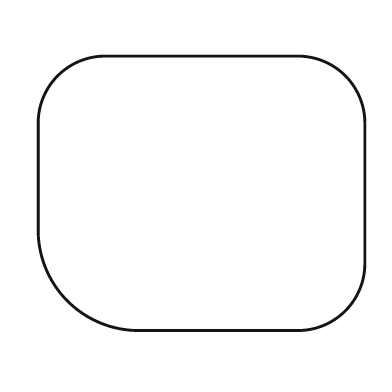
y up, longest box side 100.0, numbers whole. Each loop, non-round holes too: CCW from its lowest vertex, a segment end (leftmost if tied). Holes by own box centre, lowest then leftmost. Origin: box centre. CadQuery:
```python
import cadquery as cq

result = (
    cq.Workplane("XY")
    .moveTo(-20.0, -42.0)
    .lineTo(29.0, -42.0)
    .threePointArc((44.0, -36.0), (50.0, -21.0))
    .lineTo(50.0, 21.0)
    .threePointArc((44.0, 36.0), (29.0, 42.0))
    .lineTo(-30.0, 42.0)
    .threePointArc((-44.0, 36.0), (-50.0, 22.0))
    .lineTo(-50.0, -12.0)
    .threePointArc((-41.0, -33.0), (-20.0, -42.0))
    .close()
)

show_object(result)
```